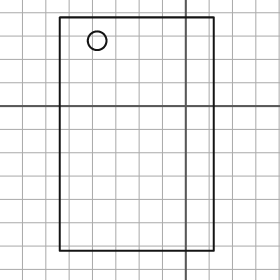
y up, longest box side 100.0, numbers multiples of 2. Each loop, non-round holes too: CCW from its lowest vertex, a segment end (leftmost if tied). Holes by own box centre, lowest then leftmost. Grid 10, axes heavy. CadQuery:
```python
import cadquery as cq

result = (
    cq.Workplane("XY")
    .moveTo(-54.0, -62.0)
    .lineTo(12.0, -62.0)
    .lineTo(12.0, 38.0)
    .lineTo(-54.0, 38.0)
    .close()
    .moveTo(-38.0, 28.0)
    .circle(4.0)
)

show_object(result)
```